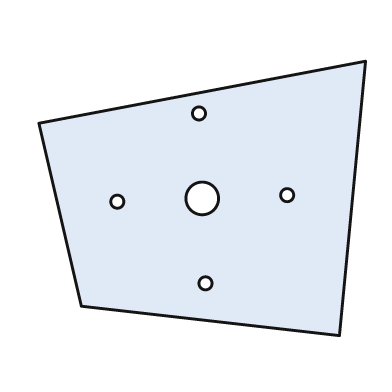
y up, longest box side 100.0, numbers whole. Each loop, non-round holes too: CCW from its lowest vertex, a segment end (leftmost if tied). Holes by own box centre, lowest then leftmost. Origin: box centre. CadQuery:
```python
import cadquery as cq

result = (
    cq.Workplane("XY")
    .moveTo(42.0, -42.0)
    .lineTo(50.0, 42.0)
    .lineTo(-50.0, 23.0)
    .lineTo(-37.0, -33.0)
    .close()
    .moveTo(1.0, -26.0)
    .circle(2.0)
    .moveTo(-26.0, -1.0)
    .circle(2.0)
    .moveTo(0.0, 0.0)
    .circle(5.0)
    .moveTo(26.0, 1.0)
    .circle(2.0)
    .moveTo(-1.0, 26.0)
    .circle(2.0)
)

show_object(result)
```